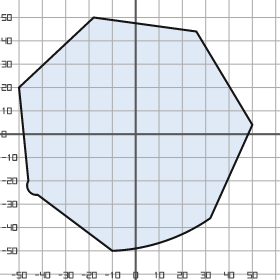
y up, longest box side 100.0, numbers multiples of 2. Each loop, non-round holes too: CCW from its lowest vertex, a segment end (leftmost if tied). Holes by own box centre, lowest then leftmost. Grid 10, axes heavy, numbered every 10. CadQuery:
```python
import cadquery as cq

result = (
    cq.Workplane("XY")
    .moveTo(-10.0, -50.0)
    .threePointArc((12.0, -46.0), (32.0, -36.0))
    .lineTo(50.0, 4.0)
    .lineTo(26.0, 44.0)
    .lineTo(-18.0, 50.0)
    .lineTo(-50.0, 20.0)
    .lineTo(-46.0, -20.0)
    .threePointArc((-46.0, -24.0), (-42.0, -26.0))
    .close()
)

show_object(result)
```